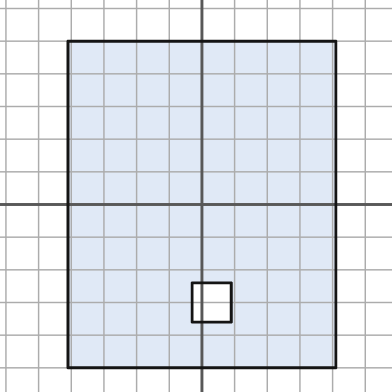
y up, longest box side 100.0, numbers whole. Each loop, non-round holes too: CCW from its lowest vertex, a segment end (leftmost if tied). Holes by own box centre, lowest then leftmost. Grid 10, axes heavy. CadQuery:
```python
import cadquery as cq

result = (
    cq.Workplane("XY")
    .moveTo(-41.0, -50.0)
    .lineTo(41.0, -50.0)
    .lineTo(41.0, 50.0)
    .lineTo(-41.0, 50.0)
    .close()
    .moveTo(-3.0, -36.0)
    .lineTo(9.0, -36.0)
    .lineTo(9.0, -24.0)
    .lineTo(-3.0, -24.0)
    .close()
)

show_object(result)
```